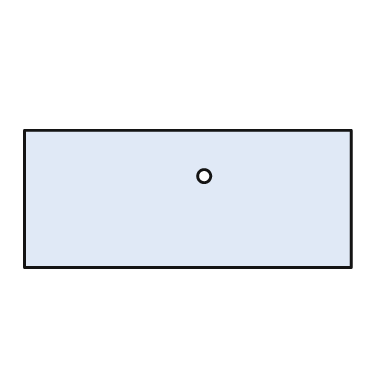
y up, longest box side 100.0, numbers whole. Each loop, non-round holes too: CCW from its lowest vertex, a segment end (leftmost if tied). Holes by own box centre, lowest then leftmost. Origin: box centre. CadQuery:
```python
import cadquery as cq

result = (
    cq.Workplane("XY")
    .moveTo(-50.0, -21.0)
    .lineTo(50.0, -21.0)
    .lineTo(50.0, 21.0)
    .lineTo(-50.0, 21.0)
    .close()
    .moveTo(5.0, 7.0)
    .circle(2.0)
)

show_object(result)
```